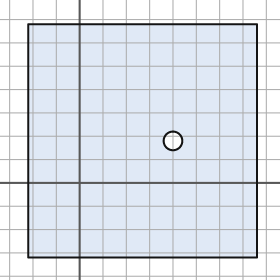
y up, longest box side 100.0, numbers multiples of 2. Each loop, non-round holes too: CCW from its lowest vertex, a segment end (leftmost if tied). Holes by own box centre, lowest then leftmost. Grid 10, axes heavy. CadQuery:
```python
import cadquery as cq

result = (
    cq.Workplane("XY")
    .moveTo(-22.0, -32.0)
    .lineTo(76.0, -32.0)
    .lineTo(76.0, 68.0)
    .lineTo(-22.0, 68.0)
    .close()
    .moveTo(40.0, 18.0)
    .circle(4.0)
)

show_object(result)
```